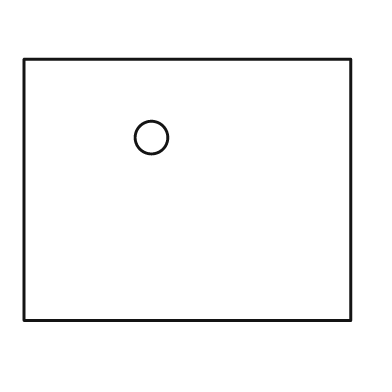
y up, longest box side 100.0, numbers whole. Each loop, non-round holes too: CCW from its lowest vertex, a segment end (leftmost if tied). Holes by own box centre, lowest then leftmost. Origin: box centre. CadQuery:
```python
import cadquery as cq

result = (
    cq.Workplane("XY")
    .moveTo(-50.0, -40.0)
    .lineTo(50.0, -40.0)
    .lineTo(50.0, 40.0)
    .lineTo(-50.0, 40.0)
    .close()
    .moveTo(-11.0, 16.0)
    .circle(5.0)
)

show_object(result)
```